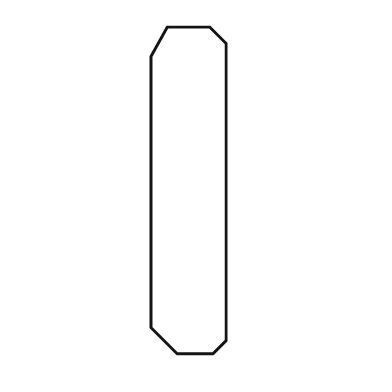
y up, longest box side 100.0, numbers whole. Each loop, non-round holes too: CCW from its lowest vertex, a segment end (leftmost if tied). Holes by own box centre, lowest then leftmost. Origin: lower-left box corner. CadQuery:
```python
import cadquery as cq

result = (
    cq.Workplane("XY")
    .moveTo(8.0, 0.0)
    .lineTo(19.0, 0.0)
    .lineTo(23.0, 4.0)
    .lineTo(23.0, 95.0)
    .lineTo(18.0, 100.0)
    .lineTo(5.0, 100.0)
    .lineTo(0.0, 91.0)
    .lineTo(0.0, 8.0)
    .close()
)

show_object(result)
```